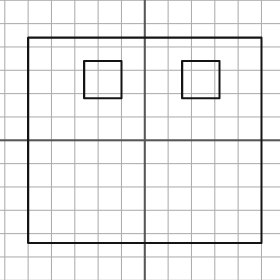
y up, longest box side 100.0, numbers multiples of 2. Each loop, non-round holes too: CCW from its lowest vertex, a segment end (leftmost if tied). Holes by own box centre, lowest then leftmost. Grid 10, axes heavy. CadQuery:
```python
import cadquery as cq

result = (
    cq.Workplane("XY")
    .moveTo(-50.0, -44.0)
    .lineTo(50.0, -44.0)
    .lineTo(50.0, 44.0)
    .lineTo(-50.0, 44.0)
    .close()
    .moveTo(-26.0, 18.0)
    .lineTo(-10.0, 18.0)
    .lineTo(-10.0, 34.0)
    .lineTo(-26.0, 34.0)
    .close()
    .moveTo(16.0, 18.0)
    .lineTo(32.0, 18.0)
    .lineTo(32.0, 34.0)
    .lineTo(16.0, 34.0)
    .close()
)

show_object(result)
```